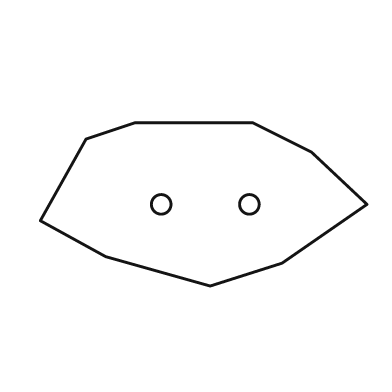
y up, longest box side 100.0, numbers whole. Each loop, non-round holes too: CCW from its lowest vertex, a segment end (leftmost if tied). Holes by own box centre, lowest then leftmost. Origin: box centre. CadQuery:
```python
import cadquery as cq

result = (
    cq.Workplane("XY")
    .moveTo(2.0, -25.0)
    .lineTo(24.0, -18.0)
    .lineTo(50.0, 0.0)
    .lineTo(33.0, 16.0)
    .lineTo(15.0, 25.0)
    .lineTo(-21.0, 25.0)
    .lineTo(-36.0, 20.0)
    .lineTo(-50.0, -5.0)
    .lineTo(-30.0, -16.0)
    .close()
    .moveTo(-13.0, 0.0)
    .circle(3.0)
    .moveTo(14.0, 0.0)
    .circle(3.0)
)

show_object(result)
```